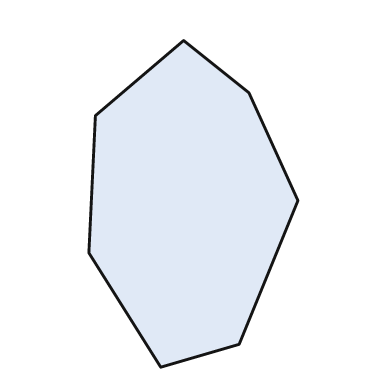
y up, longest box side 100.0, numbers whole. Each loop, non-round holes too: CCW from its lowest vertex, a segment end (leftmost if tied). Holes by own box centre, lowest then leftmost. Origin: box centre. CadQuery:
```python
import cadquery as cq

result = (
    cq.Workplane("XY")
    .moveTo(-10.0, -50.0)
    .lineTo(14.0, -43.0)
    .lineTo(32.0, 1.0)
    .lineTo(17.0, 34.0)
    .lineTo(-3.0, 50.0)
    .lineTo(-30.0, 27.0)
    .lineTo(-32.0, -15.0)
    .close()
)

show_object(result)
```